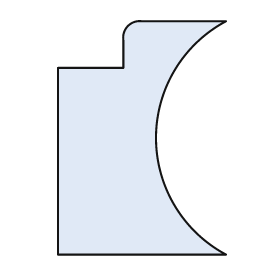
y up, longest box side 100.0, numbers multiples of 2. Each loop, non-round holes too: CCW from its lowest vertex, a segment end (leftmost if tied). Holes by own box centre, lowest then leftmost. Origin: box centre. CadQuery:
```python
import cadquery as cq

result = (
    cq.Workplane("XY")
    .moveTo(-36.0, -50.0)
    .lineTo(36.0, -50.0)
    .threePointArc((6.0, 0.0), (36.0, 50.0))
    .lineTo(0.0, 50.0)
    .threePointArc((-6.0, 48.0), (-8.0, 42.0))
    .lineTo(-8.0, 30.0)
    .lineTo(-36.0, 30.0)
    .close()
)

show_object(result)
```